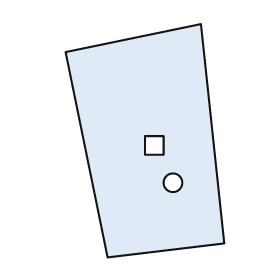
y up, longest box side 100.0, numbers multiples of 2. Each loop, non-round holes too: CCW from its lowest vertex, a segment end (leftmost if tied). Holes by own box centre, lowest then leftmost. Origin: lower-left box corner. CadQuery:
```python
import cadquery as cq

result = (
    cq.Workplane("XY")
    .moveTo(18.0, 0.0)
    .lineTo(68.0, 6.0)
    .lineTo(58.0, 100.0)
    .lineTo(0.0, 88.0)
    .close()
    .moveTo(46.0, 32.0)
    .circle(4.0)
    .moveTo(34.0, 44.0)
    .lineTo(42.0, 44.0)
    .lineTo(42.0, 52.0)
    .lineTo(34.0, 52.0)
    .close()
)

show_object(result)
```